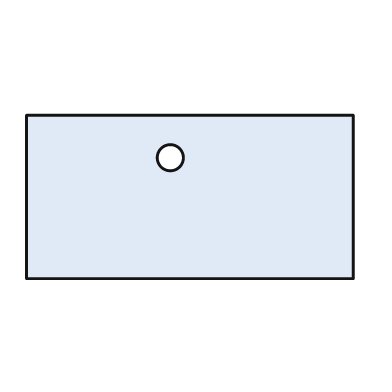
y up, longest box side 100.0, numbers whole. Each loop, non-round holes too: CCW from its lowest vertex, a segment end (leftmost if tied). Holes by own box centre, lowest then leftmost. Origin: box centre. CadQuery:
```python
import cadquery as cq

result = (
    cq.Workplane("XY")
    .moveTo(-50.0, -25.0)
    .lineTo(50.0, -25.0)
    .lineTo(50.0, 25.0)
    .lineTo(-50.0, 25.0)
    .close()
    .moveTo(-6.0, 12.0)
    .circle(4.0)
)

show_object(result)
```